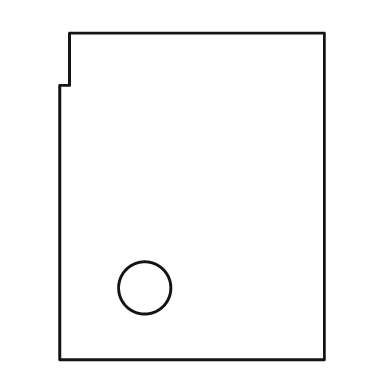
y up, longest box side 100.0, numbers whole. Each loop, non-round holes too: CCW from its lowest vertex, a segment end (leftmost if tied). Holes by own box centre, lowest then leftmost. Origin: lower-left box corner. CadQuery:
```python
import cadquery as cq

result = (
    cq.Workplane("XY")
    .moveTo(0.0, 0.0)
    .lineTo(81.0, 0.0)
    .lineTo(81.0, 100.0)
    .lineTo(3.0, 100.0)
    .lineTo(3.0, 84.0)
    .lineTo(0.0, 84.0)
    .close()
    .moveTo(26.0, 22.0)
    .circle(8.0)
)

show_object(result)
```